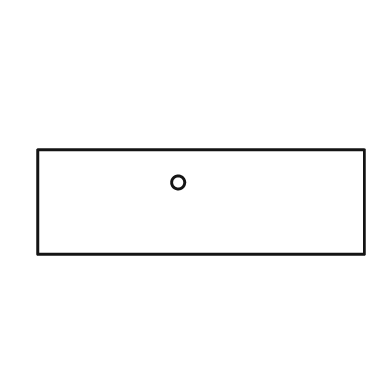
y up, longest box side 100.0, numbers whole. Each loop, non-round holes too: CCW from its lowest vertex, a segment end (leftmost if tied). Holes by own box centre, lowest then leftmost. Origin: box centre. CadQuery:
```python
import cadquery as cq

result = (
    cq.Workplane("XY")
    .moveTo(-50.0, -16.0)
    .lineTo(50.0, -16.0)
    .lineTo(50.0, 16.0)
    .lineTo(-50.0, 16.0)
    .close()
    .moveTo(-7.0, 6.0)
    .circle(2.0)
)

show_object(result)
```